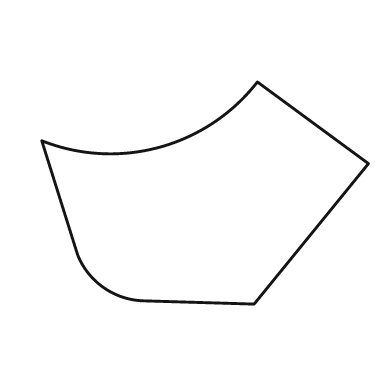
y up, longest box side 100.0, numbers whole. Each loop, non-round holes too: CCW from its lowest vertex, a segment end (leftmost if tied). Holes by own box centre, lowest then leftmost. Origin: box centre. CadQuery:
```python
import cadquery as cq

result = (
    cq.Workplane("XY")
    .moveTo(15.0, -34.0)
    .lineTo(50.0, 9.0)
    .lineTo(16.0, 34.0)
    .threePointArc((-14.0, 14.0), (-50.0, 16.0))
    .lineTo(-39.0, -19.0)
    .threePointArc((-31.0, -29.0), (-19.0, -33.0))
    .close()
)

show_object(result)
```